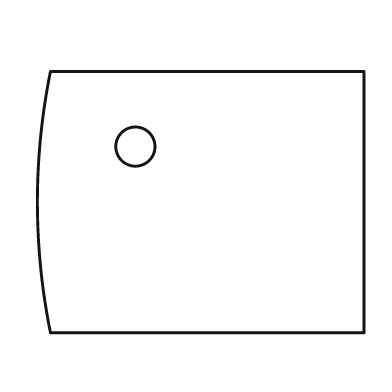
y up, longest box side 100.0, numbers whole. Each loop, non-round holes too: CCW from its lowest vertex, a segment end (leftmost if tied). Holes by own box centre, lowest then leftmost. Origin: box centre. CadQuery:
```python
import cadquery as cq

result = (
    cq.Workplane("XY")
    .moveTo(-46.0, -40.0)
    .lineTo(50.0, -40.0)
    .lineTo(50.0, 40.0)
    .lineTo(-46.0, 40.0)
    .threePointArc((-50.0, 0.0), (-46.0, -40.0))
    .close()
    .moveTo(-20.0, 17.0)
    .circle(6.0)
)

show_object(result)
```